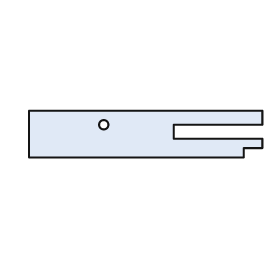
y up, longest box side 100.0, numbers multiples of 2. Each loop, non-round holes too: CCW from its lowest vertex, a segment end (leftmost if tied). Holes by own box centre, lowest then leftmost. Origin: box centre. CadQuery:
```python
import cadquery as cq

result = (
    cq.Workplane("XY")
    .moveTo(-50.0, -10.0)
    .lineTo(42.0, -10.0)
    .lineTo(42.0, -6.0)
    .lineTo(50.0, -6.0)
    .lineTo(50.0, -2.0)
    .lineTo(12.0, -2.0)
    .lineTo(12.0, 4.0)
    .lineTo(50.0, 4.0)
    .lineTo(50.0, 10.0)
    .lineTo(-50.0, 10.0)
    .close()
    .moveTo(-18.0, 4.0)
    .circle(2.0)
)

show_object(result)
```